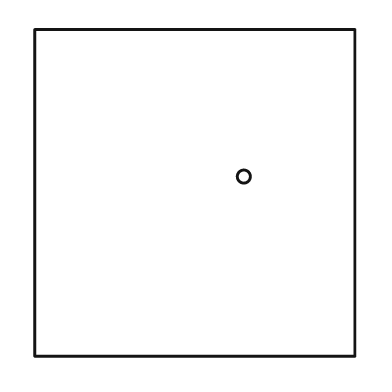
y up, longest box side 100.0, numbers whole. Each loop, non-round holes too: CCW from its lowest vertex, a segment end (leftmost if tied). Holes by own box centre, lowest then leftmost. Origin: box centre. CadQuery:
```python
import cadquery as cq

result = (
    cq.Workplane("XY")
    .moveTo(-49.0, -50.0)
    .lineTo(49.0, -50.0)
    .lineTo(49.0, 50.0)
    .lineTo(-49.0, 50.0)
    .close()
    .moveTo(15.0, 5.0)
    .circle(2.0)
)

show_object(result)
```